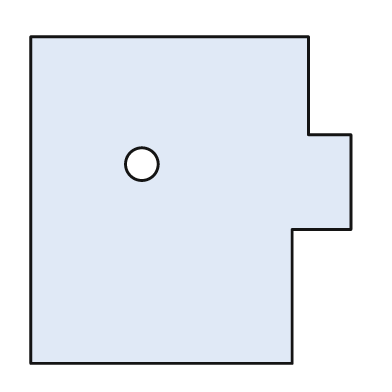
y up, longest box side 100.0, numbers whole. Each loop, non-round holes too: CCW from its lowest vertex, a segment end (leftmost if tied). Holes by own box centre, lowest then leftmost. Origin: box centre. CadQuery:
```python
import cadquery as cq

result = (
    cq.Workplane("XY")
    .moveTo(-49.0, -50.0)
    .lineTo(31.0, -50.0)
    .lineTo(31.0, -9.0)
    .lineTo(49.0, -9.0)
    .lineTo(49.0, 20.0)
    .lineTo(36.0, 20.0)
    .lineTo(36.0, 50.0)
    .lineTo(-49.0, 50.0)
    .close()
    .moveTo(-15.0, 11.0)
    .circle(5.0)
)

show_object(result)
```